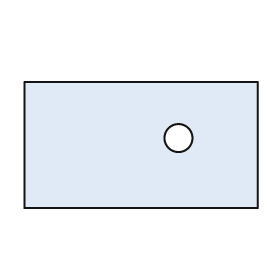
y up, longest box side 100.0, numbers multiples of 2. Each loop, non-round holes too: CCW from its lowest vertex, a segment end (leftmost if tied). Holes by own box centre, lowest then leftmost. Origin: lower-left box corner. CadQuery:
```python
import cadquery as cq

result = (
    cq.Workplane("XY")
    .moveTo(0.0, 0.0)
    .lineTo(100.0, 0.0)
    .lineTo(100.0, 54.0)
    .lineTo(0.0, 54.0)
    .close()
    .moveTo(66.0, 30.0)
    .circle(6.0)
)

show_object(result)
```